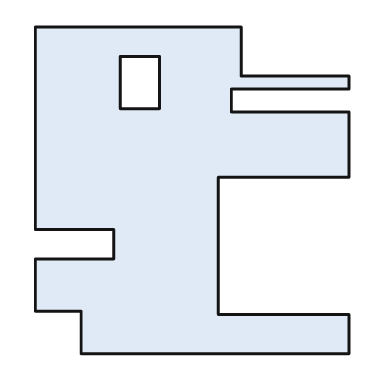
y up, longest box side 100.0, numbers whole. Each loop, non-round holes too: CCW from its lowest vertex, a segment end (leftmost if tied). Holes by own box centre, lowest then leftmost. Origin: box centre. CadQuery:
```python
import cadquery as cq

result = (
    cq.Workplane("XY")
    .moveTo(-34.0, -50.0)
    .lineTo(48.0, -50.0)
    .lineTo(48.0, -38.0)
    .lineTo(8.0, -38.0)
    .lineTo(8.0, 4.0)
    .lineTo(48.0, 4.0)
    .lineTo(48.0, 24.0)
    .lineTo(12.0, 24.0)
    .lineTo(12.0, 31.0)
    .lineTo(48.0, 31.0)
    .lineTo(48.0, 35.0)
    .lineTo(15.0, 35.0)
    .lineTo(15.0, 50.0)
    .lineTo(-48.0, 50.0)
    .lineTo(-48.0, -12.0)
    .lineTo(-24.0, -12.0)
    .lineTo(-24.0, -21.0)
    .lineTo(-48.0, -21.0)
    .lineTo(-48.0, -37.0)
    .lineTo(-34.0, -37.0)
    .close()
    .moveTo(-22.0, 25.0)
    .lineTo(-10.0, 25.0)
    .lineTo(-10.0, 41.0)
    .lineTo(-22.0, 41.0)
    .close()
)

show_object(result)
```